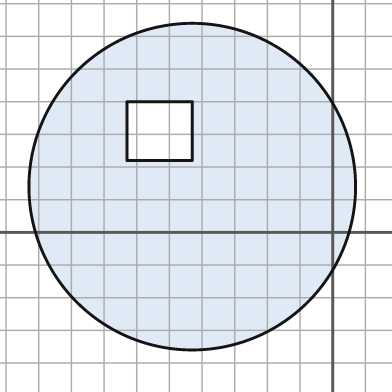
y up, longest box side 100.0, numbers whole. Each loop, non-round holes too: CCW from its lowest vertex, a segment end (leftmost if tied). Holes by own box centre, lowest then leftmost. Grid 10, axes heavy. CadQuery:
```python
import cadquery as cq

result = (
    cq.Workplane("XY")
    .moveTo(-43.0, 14.0)
    .circle(50.0)
    .moveTo(-63.0, 22.0)
    .lineTo(-43.0, 22.0)
    .lineTo(-43.0, 40.0)
    .lineTo(-63.0, 40.0)
    .close()
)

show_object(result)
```